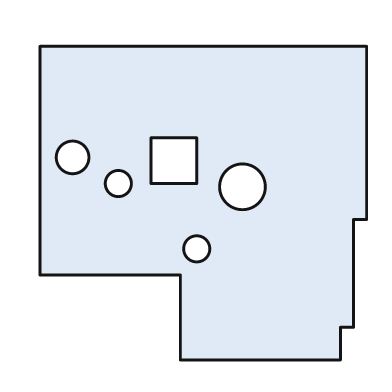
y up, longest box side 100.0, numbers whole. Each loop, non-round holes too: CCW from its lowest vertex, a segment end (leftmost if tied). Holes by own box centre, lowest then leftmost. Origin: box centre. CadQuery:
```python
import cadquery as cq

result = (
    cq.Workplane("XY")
    .moveTo(-7.0, -48.0)
    .lineTo(42.0, -48.0)
    .lineTo(42.0, -38.0)
    .lineTo(46.0, -38.0)
    .lineTo(46.0, -5.0)
    .lineTo(50.0, -5.0)
    .lineTo(50.0, 48.0)
    .lineTo(-50.0, 48.0)
    .lineTo(-50.0, -22.0)
    .lineTo(-7.0, -22.0)
    .close()
    .moveTo(-2.0, -14.0)
    .circle(4.0)
    .moveTo(12.0, 5.0)
    .circle(7.0)
    .moveTo(-26.0, 6.0)
    .circle(4.0)
    .moveTo(-16.0, 6.0)
    .lineTo(-2.0, 6.0)
    .lineTo(-2.0, 20.0)
    .lineTo(-16.0, 20.0)
    .close()
    .moveTo(-40.0, 14.0)
    .circle(5.0)
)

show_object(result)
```